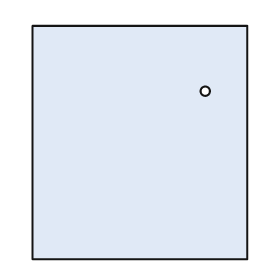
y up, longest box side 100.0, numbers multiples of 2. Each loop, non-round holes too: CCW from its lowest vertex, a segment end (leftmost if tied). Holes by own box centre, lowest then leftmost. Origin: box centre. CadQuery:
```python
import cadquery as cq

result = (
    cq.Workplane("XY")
    .moveTo(-46.0, -50.0)
    .lineTo(46.0, -50.0)
    .lineTo(46.0, 50.0)
    .lineTo(-46.0, 50.0)
    .close()
    .moveTo(28.0, 22.0)
    .circle(2.0)
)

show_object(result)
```